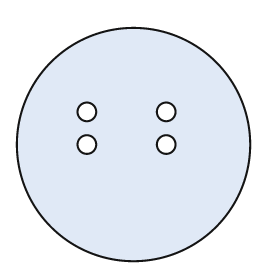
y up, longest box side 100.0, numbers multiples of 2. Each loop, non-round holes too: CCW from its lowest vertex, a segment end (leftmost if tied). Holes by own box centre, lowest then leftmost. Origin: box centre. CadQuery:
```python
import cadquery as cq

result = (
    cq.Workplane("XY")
    .moveTo(0.0, 0.0)
    .circle(50.0)
    .moveTo(-20.0, 0.0)
    .circle(4.0)
    .moveTo(14.0, 0.0)
    .circle(4.0)
    .moveTo(-20.0, 14.0)
    .circle(4.0)
    .moveTo(14.0, 14.0)
    .circle(4.0)
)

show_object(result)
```